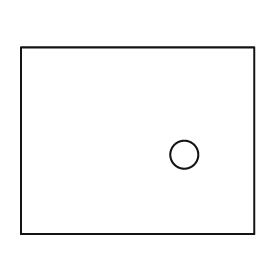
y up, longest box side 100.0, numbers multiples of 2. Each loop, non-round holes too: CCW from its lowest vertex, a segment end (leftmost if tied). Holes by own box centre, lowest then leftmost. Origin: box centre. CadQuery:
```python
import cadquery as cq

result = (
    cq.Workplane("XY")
    .moveTo(-50.0, -40.0)
    .lineTo(50.0, -40.0)
    .lineTo(50.0, 40.0)
    .lineTo(-50.0, 40.0)
    .close()
    .moveTo(20.0, -6.0)
    .circle(6.0)
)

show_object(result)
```